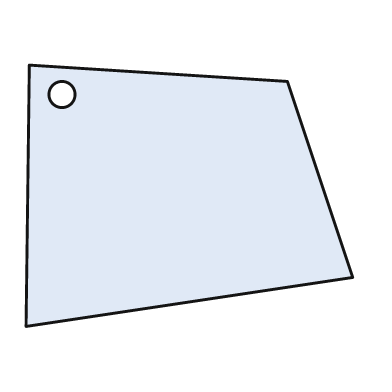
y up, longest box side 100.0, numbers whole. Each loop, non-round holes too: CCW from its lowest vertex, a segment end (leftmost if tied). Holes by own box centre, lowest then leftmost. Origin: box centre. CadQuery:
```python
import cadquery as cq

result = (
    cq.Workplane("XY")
    .moveTo(-50.0, -40.0)
    .lineTo(50.0, -25.0)
    .lineTo(30.0, 35.0)
    .lineTo(-49.0, 40.0)
    .close()
    .moveTo(-39.0, 31.0)
    .circle(4.0)
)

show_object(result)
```